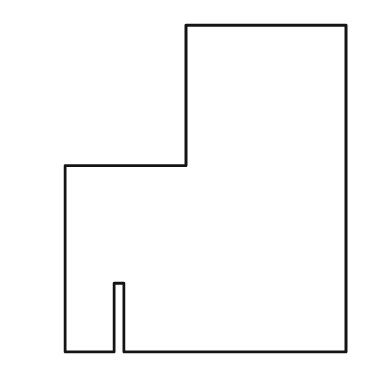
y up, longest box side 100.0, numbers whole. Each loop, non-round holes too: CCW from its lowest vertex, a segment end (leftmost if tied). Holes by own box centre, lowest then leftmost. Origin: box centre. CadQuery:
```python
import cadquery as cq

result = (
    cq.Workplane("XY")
    .moveTo(-43.0, -50.0)
    .lineTo(-28.0, -50.0)
    .lineTo(-28.0, -29.0)
    .lineTo(-25.0, -29.0)
    .lineTo(-25.0, -50.0)
    .lineTo(43.0, -50.0)
    .lineTo(43.0, 50.0)
    .lineTo(-6.0, 50.0)
    .lineTo(-6.0, 7.0)
    .lineTo(-43.0, 7.0)
    .close()
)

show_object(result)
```